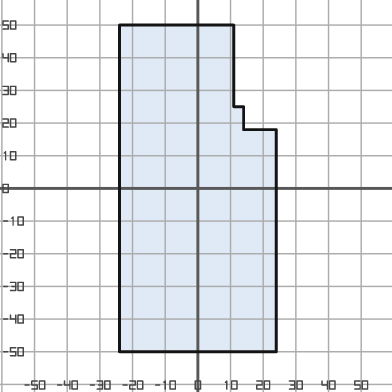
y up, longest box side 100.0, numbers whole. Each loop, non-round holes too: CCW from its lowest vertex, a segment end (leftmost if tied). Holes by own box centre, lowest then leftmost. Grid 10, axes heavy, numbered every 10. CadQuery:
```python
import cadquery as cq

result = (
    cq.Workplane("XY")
    .moveTo(-24.0, -50.0)
    .lineTo(24.0, -50.0)
    .lineTo(24.0, 18.0)
    .lineTo(14.0, 18.0)
    .lineTo(14.0, 25.0)
    .lineTo(11.0, 25.0)
    .lineTo(11.0, 50.0)
    .lineTo(-24.0, 50.0)
    .close()
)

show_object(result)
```